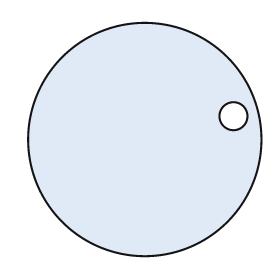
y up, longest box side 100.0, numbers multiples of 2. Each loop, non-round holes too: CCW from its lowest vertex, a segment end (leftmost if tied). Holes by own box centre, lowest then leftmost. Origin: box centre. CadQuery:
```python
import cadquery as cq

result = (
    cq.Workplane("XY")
    .moveTo(0.0, 0.0)
    .circle(50.0)
    .moveTo(38.0, 10.0)
    .circle(6.0)
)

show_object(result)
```